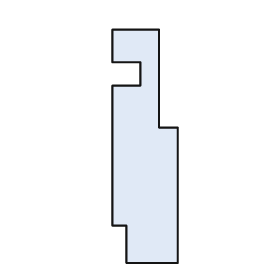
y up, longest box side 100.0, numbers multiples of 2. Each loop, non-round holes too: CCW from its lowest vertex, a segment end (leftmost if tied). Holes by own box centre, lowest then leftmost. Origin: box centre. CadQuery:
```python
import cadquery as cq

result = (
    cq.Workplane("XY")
    .moveTo(-8.0, -50.0)
    .lineTo(14.0, -50.0)
    .lineTo(14.0, 8.0)
    .lineTo(6.0, 8.0)
    .lineTo(6.0, 50.0)
    .lineTo(-14.0, 50.0)
    .lineTo(-14.0, 36.0)
    .lineTo(-2.0, 36.0)
    .lineTo(-2.0, 26.0)
    .lineTo(-14.0, 26.0)
    .lineTo(-14.0, -34.0)
    .lineTo(-8.0, -34.0)
    .close()
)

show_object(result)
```